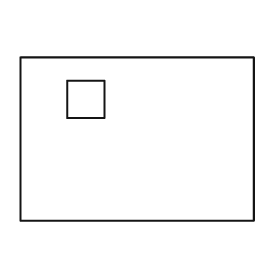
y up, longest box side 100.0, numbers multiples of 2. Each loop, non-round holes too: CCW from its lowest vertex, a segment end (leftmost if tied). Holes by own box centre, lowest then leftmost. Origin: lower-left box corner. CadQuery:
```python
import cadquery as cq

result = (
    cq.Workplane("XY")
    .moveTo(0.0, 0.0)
    .lineTo(100.0, 0.0)
    .lineTo(100.0, 70.0)
    .lineTo(0.0, 70.0)
    .close()
    .moveTo(20.0, 44.0)
    .lineTo(36.0, 44.0)
    .lineTo(36.0, 60.0)
    .lineTo(20.0, 60.0)
    .close()
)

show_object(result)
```